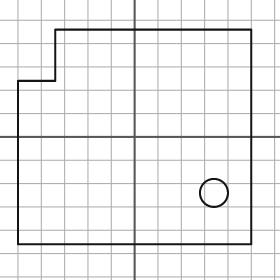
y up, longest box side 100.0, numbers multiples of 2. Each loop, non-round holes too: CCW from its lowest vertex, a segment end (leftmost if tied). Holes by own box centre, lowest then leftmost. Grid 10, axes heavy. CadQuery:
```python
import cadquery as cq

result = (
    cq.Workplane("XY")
    .moveTo(-50.0, -46.0)
    .lineTo(50.0, -46.0)
    .lineTo(50.0, 46.0)
    .lineTo(-34.0, 46.0)
    .lineTo(-34.0, 24.0)
    .lineTo(-50.0, 24.0)
    .close()
    .moveTo(34.0, -24.0)
    .circle(6.0)
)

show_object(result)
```